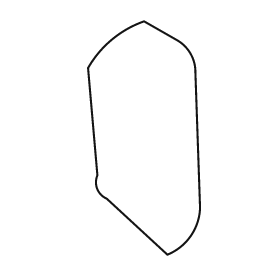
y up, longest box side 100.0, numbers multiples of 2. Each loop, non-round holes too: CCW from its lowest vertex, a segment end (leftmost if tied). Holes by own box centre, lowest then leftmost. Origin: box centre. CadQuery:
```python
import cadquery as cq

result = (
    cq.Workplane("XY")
    .moveTo(10.0, -50.0)
    .threePointArc((20.0, -42.0), (24.0, -30.0))
    .lineTo(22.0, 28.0)
    .threePointArc((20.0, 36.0), (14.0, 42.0))
    .lineTo(0.0, 50.0)
    .threePointArc((-14.0, 42.0), (-24.0, 30.0))
    .lineTo(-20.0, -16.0)
    .threePointArc((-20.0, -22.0), (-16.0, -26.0))
    .close()
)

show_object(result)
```